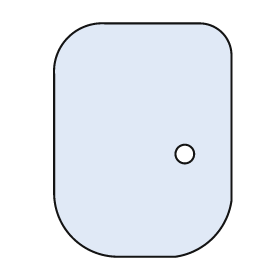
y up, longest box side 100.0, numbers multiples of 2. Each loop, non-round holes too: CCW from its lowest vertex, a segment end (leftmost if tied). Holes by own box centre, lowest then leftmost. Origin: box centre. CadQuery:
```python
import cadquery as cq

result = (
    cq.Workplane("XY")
    .moveTo(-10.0, -50.0)
    .lineTo(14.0, -50.0)
    .threePointArc((30.0, -42.0), (38.0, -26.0))
    .lineTo(38.0, 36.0)
    .threePointArc((34.0, 46.0), (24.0, 50.0))
    .lineTo(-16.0, 50.0)
    .threePointArc((-32.0, 44.0), (-38.0, 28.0))
    .lineTo(-38.0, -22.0)
    .threePointArc((-30.0, -42.0), (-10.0, -50.0))
    .close()
    .moveTo(18.0, -6.0)
    .circle(4.0)
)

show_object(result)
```